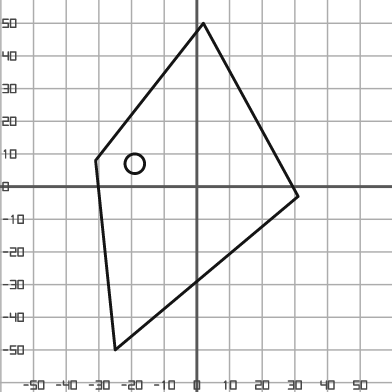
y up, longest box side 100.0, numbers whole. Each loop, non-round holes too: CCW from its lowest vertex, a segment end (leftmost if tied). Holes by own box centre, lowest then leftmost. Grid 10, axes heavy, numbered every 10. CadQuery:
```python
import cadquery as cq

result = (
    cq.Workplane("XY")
    .moveTo(-25.0, -50.0)
    .lineTo(31.0, -3.0)
    .lineTo(2.0, 50.0)
    .lineTo(-31.0, 8.0)
    .close()
    .moveTo(-19.0, 7.0)
    .circle(3.0)
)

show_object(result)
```